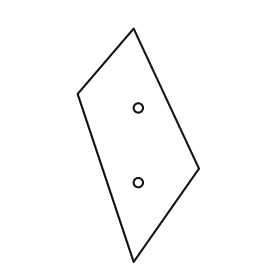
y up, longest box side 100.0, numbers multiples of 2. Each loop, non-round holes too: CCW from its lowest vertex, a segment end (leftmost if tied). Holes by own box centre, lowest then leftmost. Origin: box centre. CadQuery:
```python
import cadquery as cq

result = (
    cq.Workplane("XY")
    .moveTo(-2.0, -50.0)
    .lineTo(26.0, -10.0)
    .lineTo(-2.0, 50.0)
    .lineTo(-26.0, 22.0)
    .close()
    .moveTo(0.0, -16.0)
    .circle(2.0)
    .moveTo(0.0, 16.0)
    .circle(2.0)
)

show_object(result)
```